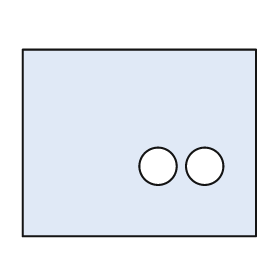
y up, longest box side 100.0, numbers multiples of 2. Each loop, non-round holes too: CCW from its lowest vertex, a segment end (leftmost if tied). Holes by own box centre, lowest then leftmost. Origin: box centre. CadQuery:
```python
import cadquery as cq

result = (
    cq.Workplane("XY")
    .moveTo(-50.0, -40.0)
    .lineTo(50.0, -40.0)
    .lineTo(50.0, 40.0)
    .lineTo(-50.0, 40.0)
    .close()
    .moveTo(8.0, -10.0)
    .circle(8.0)
    .moveTo(28.0, -10.0)
    .circle(8.0)
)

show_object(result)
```